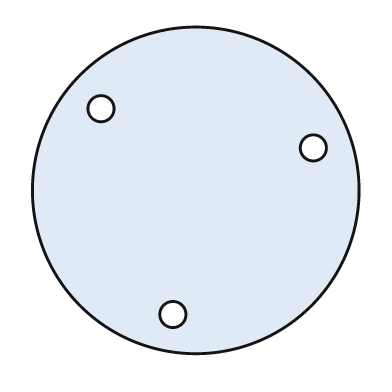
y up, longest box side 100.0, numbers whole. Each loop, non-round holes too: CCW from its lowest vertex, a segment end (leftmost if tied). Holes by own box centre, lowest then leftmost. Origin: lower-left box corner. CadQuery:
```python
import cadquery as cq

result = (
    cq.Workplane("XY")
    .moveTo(50.0, 50.0)
    .circle(50.0)
    .moveTo(43.0, 12.0)
    .circle(4.0)
    .moveTo(86.0, 63.0)
    .circle(4.0)
    .moveTo(21.0, 75.0)
    .circle(4.0)
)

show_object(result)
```